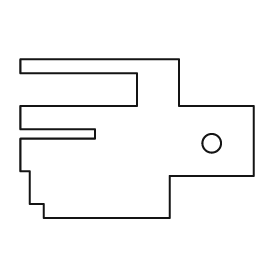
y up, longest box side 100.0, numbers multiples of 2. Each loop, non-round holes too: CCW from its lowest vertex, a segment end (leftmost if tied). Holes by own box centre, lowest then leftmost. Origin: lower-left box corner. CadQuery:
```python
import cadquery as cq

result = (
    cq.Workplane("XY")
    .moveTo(10.0, 0.0)
    .lineTo(64.0, 0.0)
    .lineTo(64.0, 18.0)
    .lineTo(100.0, 18.0)
    .lineTo(100.0, 48.0)
    .lineTo(68.0, 48.0)
    .lineTo(68.0, 68.0)
    .lineTo(0.0, 68.0)
    .lineTo(0.0, 62.0)
    .lineTo(50.0, 62.0)
    .lineTo(50.0, 48.0)
    .lineTo(0.0, 48.0)
    .lineTo(0.0, 38.0)
    .lineTo(32.0, 38.0)
    .lineTo(32.0, 34.0)
    .lineTo(0.0, 34.0)
    .lineTo(0.0, 20.0)
    .lineTo(4.0, 20.0)
    .lineTo(4.0, 6.0)
    .lineTo(10.0, 6.0)
    .close()
    .moveTo(82.0, 32.0)
    .circle(4.0)
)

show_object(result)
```